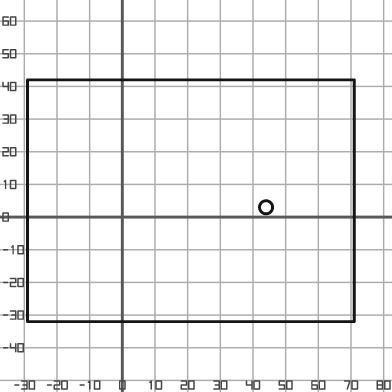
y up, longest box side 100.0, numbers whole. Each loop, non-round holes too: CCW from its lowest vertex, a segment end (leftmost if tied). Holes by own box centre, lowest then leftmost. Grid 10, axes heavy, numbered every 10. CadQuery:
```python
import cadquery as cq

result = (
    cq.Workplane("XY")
    .moveTo(-29.0, -32.0)
    .lineTo(71.0, -32.0)
    .lineTo(71.0, 42.0)
    .lineTo(-29.0, 42.0)
    .close()
    .moveTo(44.0, 3.0)
    .circle(2.0)
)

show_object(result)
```